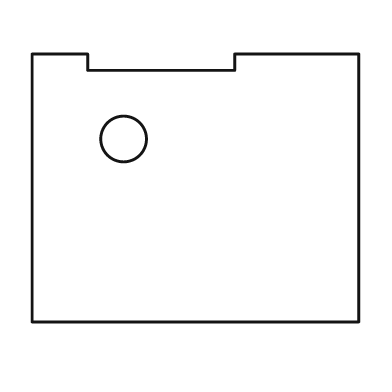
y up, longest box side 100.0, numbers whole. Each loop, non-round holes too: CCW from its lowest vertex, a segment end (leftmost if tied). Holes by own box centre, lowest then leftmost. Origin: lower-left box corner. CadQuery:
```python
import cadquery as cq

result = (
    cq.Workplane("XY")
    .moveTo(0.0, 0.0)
    .lineTo(100.0, 0.0)
    .lineTo(100.0, 82.0)
    .lineTo(62.0, 82.0)
    .lineTo(62.0, 77.0)
    .lineTo(17.0, 77.0)
    .lineTo(17.0, 82.0)
    .lineTo(0.0, 82.0)
    .close()
    .moveTo(28.0, 56.0)
    .circle(7.0)
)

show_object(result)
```